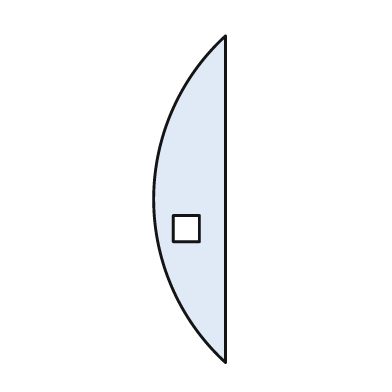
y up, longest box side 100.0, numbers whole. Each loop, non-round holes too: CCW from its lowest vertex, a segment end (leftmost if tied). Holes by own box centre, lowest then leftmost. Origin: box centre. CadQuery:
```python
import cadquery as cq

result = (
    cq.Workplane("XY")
    .moveTo(11.0, -50.0)
    .lineTo(11.0, 50.0)
    .threePointArc((-11.0, 0.0), (11.0, -50.0))
    .close()
    .moveTo(-5.0, -13.0)
    .lineTo(3.0, -13.0)
    .lineTo(3.0, -5.0)
    .lineTo(-5.0, -5.0)
    .close()
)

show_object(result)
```